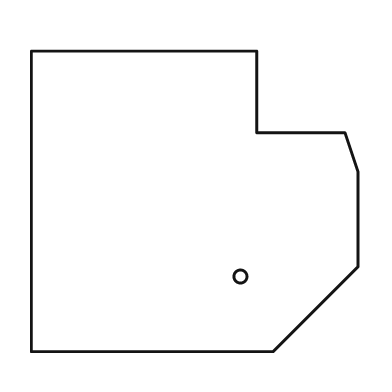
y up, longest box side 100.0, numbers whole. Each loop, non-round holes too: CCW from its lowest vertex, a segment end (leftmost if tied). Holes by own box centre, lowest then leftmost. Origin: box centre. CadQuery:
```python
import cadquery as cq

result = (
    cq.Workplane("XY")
    .moveTo(-50.0, -46.0)
    .lineTo(24.0, -46.0)
    .lineTo(50.0, -20.0)
    .lineTo(50.0, 9.0)
    .lineTo(46.0, 21.0)
    .lineTo(19.0, 21.0)
    .lineTo(19.0, 46.0)
    .lineTo(-50.0, 46.0)
    .close()
    .moveTo(14.0, -23.0)
    .circle(2.0)
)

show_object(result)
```